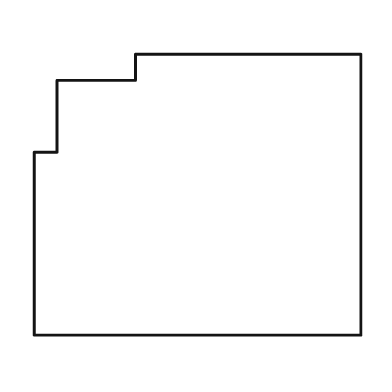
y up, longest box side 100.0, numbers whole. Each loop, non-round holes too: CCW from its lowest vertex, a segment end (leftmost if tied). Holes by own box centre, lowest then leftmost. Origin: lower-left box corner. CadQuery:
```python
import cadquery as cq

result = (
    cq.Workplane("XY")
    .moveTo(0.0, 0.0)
    .lineTo(100.0, 0.0)
    .lineTo(100.0, 86.0)
    .lineTo(31.0, 86.0)
    .lineTo(31.0, 78.0)
    .lineTo(7.0, 78.0)
    .lineTo(7.0, 56.0)
    .lineTo(0.0, 56.0)
    .close()
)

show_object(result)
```